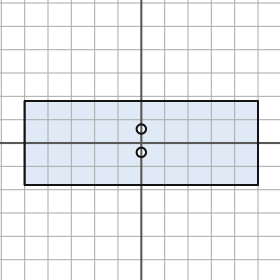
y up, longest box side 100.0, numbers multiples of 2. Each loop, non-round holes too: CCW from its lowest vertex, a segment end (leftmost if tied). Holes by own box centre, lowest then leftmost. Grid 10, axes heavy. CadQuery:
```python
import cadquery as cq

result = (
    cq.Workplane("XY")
    .moveTo(-50.0, -18.0)
    .lineTo(50.0, -18.0)
    .lineTo(50.0, 18.0)
    .lineTo(-50.0, 18.0)
    .close()
    .moveTo(0.0, -4.0)
    .circle(2.0)
    .moveTo(0.0, 6.0)
    .circle(2.0)
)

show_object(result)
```